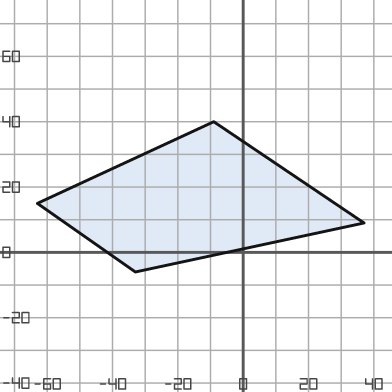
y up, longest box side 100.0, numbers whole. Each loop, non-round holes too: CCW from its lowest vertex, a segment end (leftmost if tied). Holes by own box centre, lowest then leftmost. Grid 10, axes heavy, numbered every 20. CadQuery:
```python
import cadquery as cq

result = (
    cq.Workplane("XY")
    .moveTo(-33.0, -6.0)
    .lineTo(37.0, 9.0)
    .lineTo(-9.0, 40.0)
    .lineTo(-63.0, 15.0)
    .close()
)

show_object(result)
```